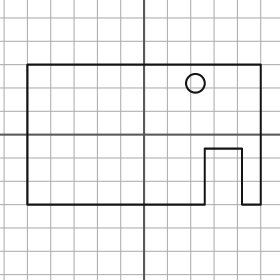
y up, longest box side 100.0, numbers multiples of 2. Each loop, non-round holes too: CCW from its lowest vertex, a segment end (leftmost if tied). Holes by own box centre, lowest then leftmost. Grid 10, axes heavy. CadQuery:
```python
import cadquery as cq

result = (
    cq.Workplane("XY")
    .moveTo(-50.0, -30.0)
    .lineTo(26.0, -30.0)
    .lineTo(26.0, -6.0)
    .lineTo(42.0, -6.0)
    .lineTo(42.0, -30.0)
    .lineTo(50.0, -30.0)
    .lineTo(50.0, 30.0)
    .lineTo(-50.0, 30.0)
    .close()
    .moveTo(22.0, 22.0)
    .circle(4.0)
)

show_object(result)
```